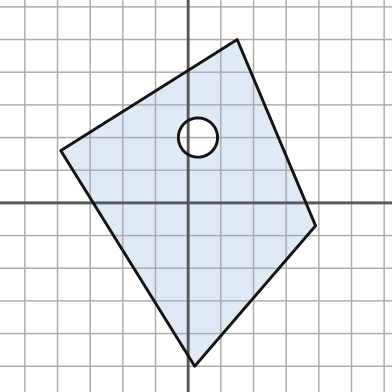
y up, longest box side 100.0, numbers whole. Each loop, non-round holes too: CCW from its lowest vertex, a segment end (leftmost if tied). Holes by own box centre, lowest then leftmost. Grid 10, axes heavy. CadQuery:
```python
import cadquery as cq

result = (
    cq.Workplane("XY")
    .moveTo(2.0, -50.0)
    .lineTo(39.0, -7.0)
    .lineTo(15.0, 50.0)
    .lineTo(-39.0, 16.0)
    .close()
    .moveTo(3.0, 20.0)
    .circle(6.0)
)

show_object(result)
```